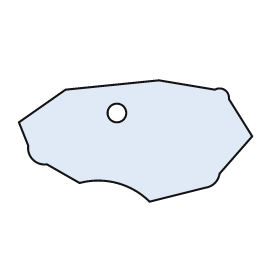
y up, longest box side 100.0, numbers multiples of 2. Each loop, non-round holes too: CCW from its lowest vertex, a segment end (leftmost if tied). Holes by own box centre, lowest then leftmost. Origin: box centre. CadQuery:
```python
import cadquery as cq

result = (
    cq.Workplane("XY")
    .moveTo(6.0, -26.0)
    .lineTo(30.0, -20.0)
    .threePointArc((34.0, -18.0), (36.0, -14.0))
    .lineTo(50.0, 2.0)
    .lineTo(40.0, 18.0)
    .threePointArc((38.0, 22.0), (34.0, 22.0))
    .lineTo(10.0, 26.0)
    .lineTo(-30.0, 22.0)
    .lineTo(-50.0, 8.0)
    .lineTo(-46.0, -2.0)
    .threePointArc((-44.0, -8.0), (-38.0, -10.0))
    .lineTo(-24.0, -18.0)
    .threePointArc((-8.0, -18.0), (6.0, -26.0))
    .close()
    .moveTo(-8.0, 12.0)
    .circle(4.0)
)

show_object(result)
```